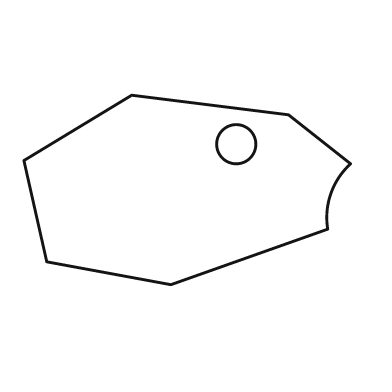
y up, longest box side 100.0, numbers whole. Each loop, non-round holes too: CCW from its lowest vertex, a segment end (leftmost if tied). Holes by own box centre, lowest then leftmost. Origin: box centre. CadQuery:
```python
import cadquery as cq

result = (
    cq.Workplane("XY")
    .moveTo(-5.0, -29.0)
    .lineTo(43.0, -12.0)
    .threePointArc((44.0, -1.0), (50.0, 8.0))
    .lineTo(31.0, 23.0)
    .lineTo(-17.0, 29.0)
    .lineTo(-50.0, 9.0)
    .lineTo(-43.0, -22.0)
    .close()
    .moveTo(15.0, 14.0)
    .circle(6.0)
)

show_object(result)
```